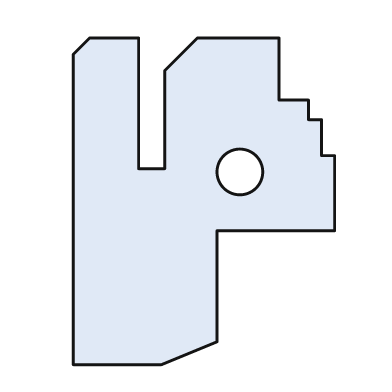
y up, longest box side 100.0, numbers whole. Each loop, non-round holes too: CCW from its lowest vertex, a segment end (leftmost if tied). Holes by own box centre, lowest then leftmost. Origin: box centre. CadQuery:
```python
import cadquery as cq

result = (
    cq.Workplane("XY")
    .moveTo(-40.0, -50.0)
    .lineTo(-13.0, -50.0)
    .lineTo(4.0, -43.0)
    .lineTo(4.0, -9.0)
    .lineTo(40.0, -9.0)
    .lineTo(40.0, 14.0)
    .lineTo(36.0, 14.0)
    .lineTo(36.0, 25.0)
    .lineTo(32.0, 25.0)
    .lineTo(32.0, 31.0)
    .lineTo(23.0, 31.0)
    .lineTo(23.0, 50.0)
    .lineTo(-2.0, 50.0)
    .lineTo(-12.0, 40.0)
    .lineTo(-12.0, 10.0)
    .lineTo(-20.0, 10.0)
    .lineTo(-20.0, 50.0)
    .lineTo(-35.0, 50.0)
    .lineTo(-40.0, 45.0)
    .close()
    .moveTo(11.0, 9.0)
    .circle(7.0)
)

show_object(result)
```